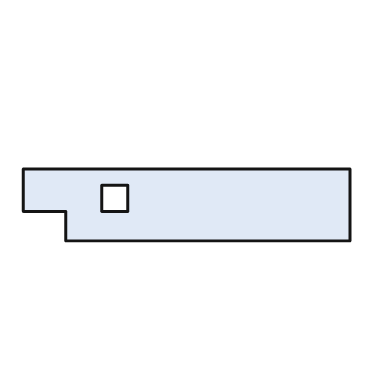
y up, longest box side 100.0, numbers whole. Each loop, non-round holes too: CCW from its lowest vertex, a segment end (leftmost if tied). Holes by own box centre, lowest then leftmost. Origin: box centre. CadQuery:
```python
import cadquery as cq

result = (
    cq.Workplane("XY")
    .moveTo(-37.0, -11.0)
    .lineTo(50.0, -11.0)
    .lineTo(50.0, 11.0)
    .lineTo(-50.0, 11.0)
    .lineTo(-50.0, -2.0)
    .lineTo(-37.0, -2.0)
    .close()
    .moveTo(-26.0, -2.0)
    .lineTo(-18.0, -2.0)
    .lineTo(-18.0, 6.0)
    .lineTo(-26.0, 6.0)
    .close()
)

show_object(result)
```